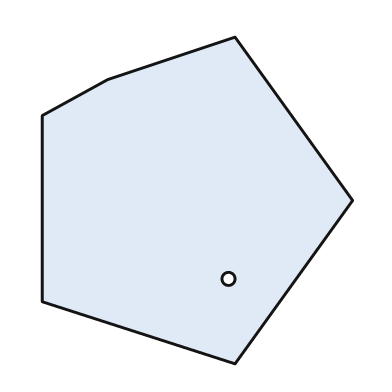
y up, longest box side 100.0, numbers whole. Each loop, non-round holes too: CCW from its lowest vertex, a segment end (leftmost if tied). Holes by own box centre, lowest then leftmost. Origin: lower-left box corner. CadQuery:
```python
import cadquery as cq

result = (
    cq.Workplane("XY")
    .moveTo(59.0, 0.0)
    .lineTo(95.0, 50.0)
    .lineTo(59.0, 100.0)
    .lineTo(20.0, 87.0)
    .lineTo(0.0, 76.0)
    .lineTo(0.0, 19.0)
    .close()
    .moveTo(57.0, 26.0)
    .circle(2.0)
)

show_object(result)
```